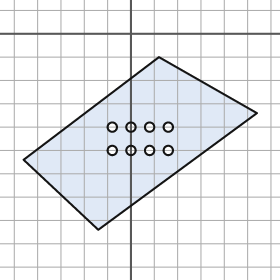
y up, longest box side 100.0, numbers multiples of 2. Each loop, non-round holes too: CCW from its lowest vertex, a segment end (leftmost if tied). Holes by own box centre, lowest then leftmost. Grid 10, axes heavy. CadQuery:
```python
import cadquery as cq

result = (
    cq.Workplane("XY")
    .moveTo(-14.0, -84.0)
    .lineTo(54.0, -34.0)
    .lineTo(12.0, -10.0)
    .lineTo(-46.0, -54.0)
    .close()
    .moveTo(-8.0, -50.0)
    .circle(2.0)
    .moveTo(0.0, -50.0)
    .circle(2.0)
    .moveTo(8.0, -50.0)
    .circle(2.0)
    .moveTo(16.0, -50.0)
    .circle(2.0)
    .moveTo(-8.0, -40.0)
    .circle(2.0)
    .moveTo(0.0, -40.0)
    .circle(2.0)
    .moveTo(8.0, -40.0)
    .circle(2.0)
    .moveTo(16.0, -40.0)
    .circle(2.0)
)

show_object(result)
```